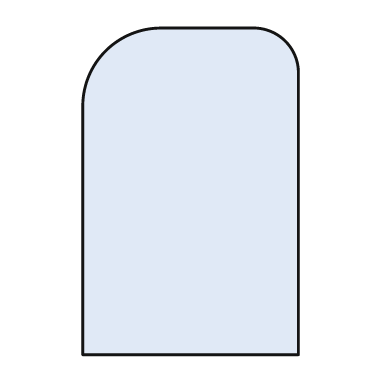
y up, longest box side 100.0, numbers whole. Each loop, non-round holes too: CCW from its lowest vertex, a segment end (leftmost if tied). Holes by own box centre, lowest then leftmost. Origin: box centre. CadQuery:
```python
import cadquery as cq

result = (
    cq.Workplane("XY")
    .moveTo(-33.0, -50.0)
    .lineTo(33.0, -50.0)
    .lineTo(33.0, 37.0)
    .threePointArc((29.0, 46.0), (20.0, 50.0))
    .lineTo(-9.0, 50.0)
    .threePointArc((-26.0, 43.0), (-33.0, 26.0))
    .close()
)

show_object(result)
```